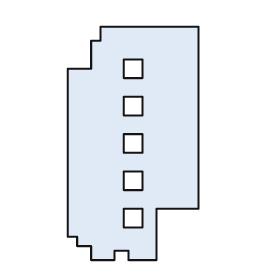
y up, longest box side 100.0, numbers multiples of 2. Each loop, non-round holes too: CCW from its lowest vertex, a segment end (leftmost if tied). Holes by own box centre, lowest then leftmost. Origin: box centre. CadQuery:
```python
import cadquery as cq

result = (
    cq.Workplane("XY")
    .moveTo(-18.0, -50.0)
    .lineTo(-8.0, -50.0)
    .lineTo(-8.0, -46.0)
    .lineTo(-2.0, -46.0)
    .lineTo(-2.0, -50.0)
    .lineTo(10.0, -50.0)
    .lineTo(10.0, -28.0)
    .lineTo(28.0, -28.0)
    .lineTo(28.0, 50.0)
    .lineTo(-14.0, 50.0)
    .lineTo(-14.0, 44.0)
    .lineTo(-18.0, 44.0)
    .lineTo(-18.0, 32.0)
    .lineTo(-28.0, 32.0)
    .lineTo(-28.0, -40.0)
    .lineTo(-24.0, -40.0)
    .lineTo(-24.0, -44.0)
    .lineTo(-18.0, -44.0)
    .close()
    .moveTo(-4.0, -36.0)
    .lineTo(4.0, -36.0)
    .lineTo(4.0, -28.0)
    .lineTo(-4.0, -28.0)
    .close()
    .moveTo(-4.0, -20.0)
    .lineTo(4.0, -20.0)
    .lineTo(4.0, -12.0)
    .lineTo(-4.0, -12.0)
    .close()
    .moveTo(-4.0, -4.0)
    .lineTo(4.0, -4.0)
    .lineTo(4.0, 4.0)
    .lineTo(-4.0, 4.0)
    .close()
    .moveTo(-4.0, 12.0)
    .lineTo(4.0, 12.0)
    .lineTo(4.0, 20.0)
    .lineTo(-4.0, 20.0)
    .close()
    .moveTo(-4.0, 28.0)
    .lineTo(4.0, 28.0)
    .lineTo(4.0, 36.0)
    .lineTo(-4.0, 36.0)
    .close()
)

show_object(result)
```